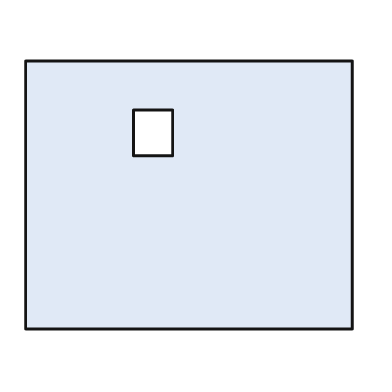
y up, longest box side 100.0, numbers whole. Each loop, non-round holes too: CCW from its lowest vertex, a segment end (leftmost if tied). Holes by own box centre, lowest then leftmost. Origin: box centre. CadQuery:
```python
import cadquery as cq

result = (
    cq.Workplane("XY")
    .moveTo(-50.0, -41.0)
    .lineTo(50.0, -41.0)
    .lineTo(50.0, 41.0)
    .lineTo(-50.0, 41.0)
    .close()
    .moveTo(-17.0, 12.0)
    .lineTo(-5.0, 12.0)
    .lineTo(-5.0, 26.0)
    .lineTo(-17.0, 26.0)
    .close()
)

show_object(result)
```